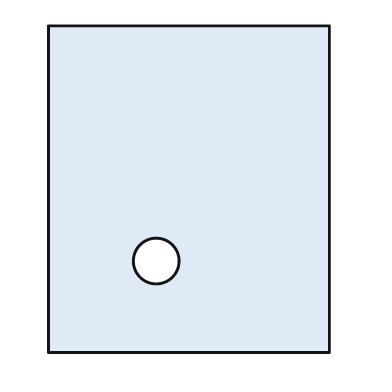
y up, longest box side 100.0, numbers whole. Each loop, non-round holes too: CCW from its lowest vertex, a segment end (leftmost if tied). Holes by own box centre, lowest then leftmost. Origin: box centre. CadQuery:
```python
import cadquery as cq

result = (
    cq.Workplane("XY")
    .moveTo(-43.0, -50.0)
    .lineTo(43.0, -50.0)
    .lineTo(43.0, 50.0)
    .lineTo(-43.0, 50.0)
    .close()
    .moveTo(-10.0, -22.0)
    .circle(7.0)
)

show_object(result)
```